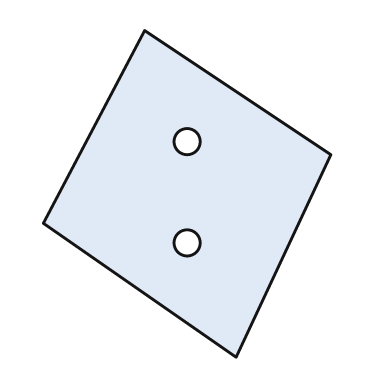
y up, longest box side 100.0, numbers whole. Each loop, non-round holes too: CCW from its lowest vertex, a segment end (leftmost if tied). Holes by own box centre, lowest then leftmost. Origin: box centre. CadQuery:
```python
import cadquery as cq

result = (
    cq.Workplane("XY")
    .moveTo(15.0, -50.0)
    .lineTo(44.0, 12.0)
    .lineTo(-13.0, 50.0)
    .lineTo(-44.0, -9.0)
    .close()
    .moveTo(0.0, -15.0)
    .circle(4.0)
    .moveTo(0.0, 16.0)
    .circle(4.0)
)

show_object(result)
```